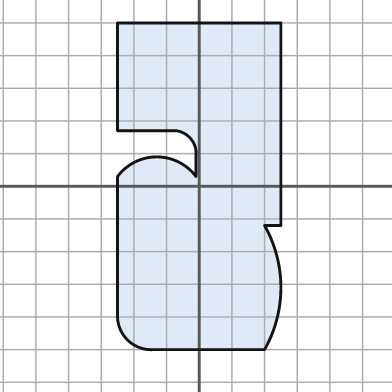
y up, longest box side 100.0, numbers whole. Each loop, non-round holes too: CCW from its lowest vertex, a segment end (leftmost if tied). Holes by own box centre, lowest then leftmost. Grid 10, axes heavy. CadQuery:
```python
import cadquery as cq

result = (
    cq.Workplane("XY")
    .moveTo(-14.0, -50.0)
    .lineTo(20.0, -50.0)
    .threePointArc((25.0, -31.0), (20.0, -12.0))
    .lineTo(25.0, -12.0)
    .lineTo(25.0, 50.0)
    .lineTo(-25.0, 50.0)
    .lineTo(-25.0, 17.0)
    .lineTo(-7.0, 17.0)
    .threePointArc((-3.0, 15.0), (-1.0, 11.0))
    .lineTo(-1.0, 3.0)
    .threePointArc((-13.0, 9.0), (-25.0, 3.0))
    .lineTo(-25.0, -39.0)
    .threePointArc((-22.0, -47.0), (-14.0, -50.0))
    .close()
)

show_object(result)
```